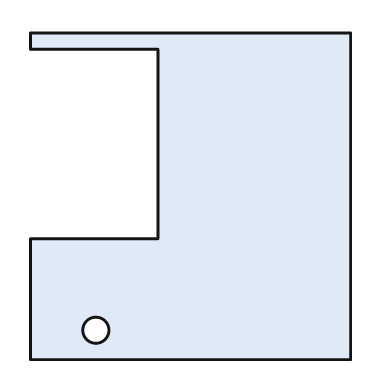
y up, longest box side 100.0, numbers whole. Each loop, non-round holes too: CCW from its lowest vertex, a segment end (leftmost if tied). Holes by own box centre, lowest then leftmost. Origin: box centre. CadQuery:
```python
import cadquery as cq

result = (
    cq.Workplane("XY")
    .moveTo(-49.0, -50.0)
    .lineTo(49.0, -50.0)
    .lineTo(49.0, 50.0)
    .lineTo(-49.0, 50.0)
    .lineTo(-49.0, 45.0)
    .lineTo(-10.0, 45.0)
    .lineTo(-10.0, -13.0)
    .lineTo(-49.0, -13.0)
    .close()
    .moveTo(-29.0, -41.0)
    .circle(4.0)
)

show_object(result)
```